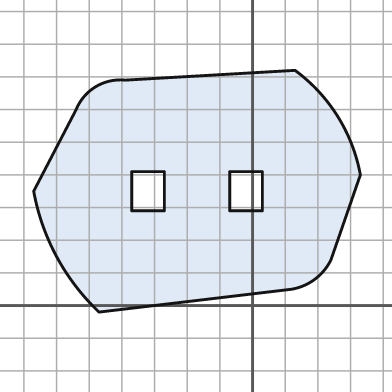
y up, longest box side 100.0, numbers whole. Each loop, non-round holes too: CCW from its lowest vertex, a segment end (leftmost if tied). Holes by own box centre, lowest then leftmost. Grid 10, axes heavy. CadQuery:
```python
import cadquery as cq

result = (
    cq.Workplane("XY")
    .moveTo(-47.0, -2.0)
    .lineTo(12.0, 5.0)
    .threePointArc((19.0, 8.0), (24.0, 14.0))
    .lineTo(33.0, 40.0)
    .threePointArc((26.0, 58.0), (13.0, 72.0))
    .lineTo(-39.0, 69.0)
    .threePointArc((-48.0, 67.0), (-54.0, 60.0))
    .lineTo(-67.0, 35.0)
    .threePointArc((-60.0, 15.0), (-47.0, -2.0))
    .close()
    .moveTo(-37.0, 29.0)
    .lineTo(-27.0, 29.0)
    .lineTo(-27.0, 41.0)
    .lineTo(-37.0, 41.0)
    .close()
    .moveTo(-7.0, 29.0)
    .lineTo(3.0, 29.0)
    .lineTo(3.0, 41.0)
    .lineTo(-7.0, 41.0)
    .close()
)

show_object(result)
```